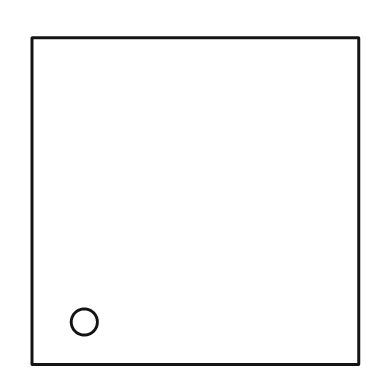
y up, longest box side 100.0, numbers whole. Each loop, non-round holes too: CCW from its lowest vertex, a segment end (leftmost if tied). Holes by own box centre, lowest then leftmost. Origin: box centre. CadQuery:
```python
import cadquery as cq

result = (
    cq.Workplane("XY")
    .moveTo(-50.0, -50.0)
    .lineTo(50.0, -50.0)
    .lineTo(50.0, 50.0)
    .lineTo(-50.0, 50.0)
    .close()
    .moveTo(-34.0, -37.0)
    .circle(4.0)
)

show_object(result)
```